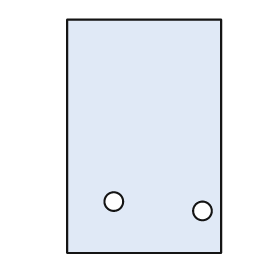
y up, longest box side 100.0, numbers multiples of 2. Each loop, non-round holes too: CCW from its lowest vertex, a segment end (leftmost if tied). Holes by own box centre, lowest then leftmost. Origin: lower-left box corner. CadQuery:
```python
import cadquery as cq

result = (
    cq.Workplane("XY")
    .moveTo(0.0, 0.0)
    .lineTo(66.0, 0.0)
    .lineTo(66.0, 100.0)
    .lineTo(0.0, 100.0)
    .close()
    .moveTo(58.0, 18.0)
    .circle(4.0)
    .moveTo(20.0, 22.0)
    .circle(4.0)
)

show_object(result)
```